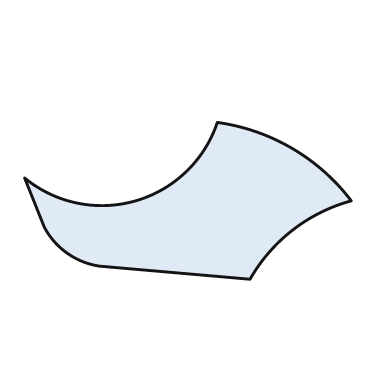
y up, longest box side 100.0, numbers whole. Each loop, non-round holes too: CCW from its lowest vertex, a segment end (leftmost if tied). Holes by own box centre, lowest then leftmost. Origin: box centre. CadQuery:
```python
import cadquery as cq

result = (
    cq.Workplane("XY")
    .moveTo(19.0, -24.0)
    .threePointArc((32.0, -9.0), (50.0, 0.0))
    .threePointArc((32.0, 16.0), (9.0, 24.0))
    .threePointArc((-16.0, 0.0), (-50.0, 7.0))
    .lineTo(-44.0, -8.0)
    .threePointArc((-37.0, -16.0), (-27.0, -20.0))
    .close()
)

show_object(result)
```